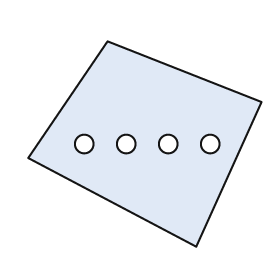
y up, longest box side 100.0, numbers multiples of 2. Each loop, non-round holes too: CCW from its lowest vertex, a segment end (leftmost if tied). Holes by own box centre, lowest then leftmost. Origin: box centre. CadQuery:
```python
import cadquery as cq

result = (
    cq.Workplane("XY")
    .moveTo(22.0, -44.0)
    .lineTo(50.0, 18.0)
    .lineTo(-16.0, 44.0)
    .lineTo(-50.0, -6.0)
    .close()
    .moveTo(-26.0, 0.0)
    .circle(4.0)
    .moveTo(-8.0, 0.0)
    .circle(4.0)
    .moveTo(10.0, 0.0)
    .circle(4.0)
    .moveTo(28.0, 0.0)
    .circle(4.0)
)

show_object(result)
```